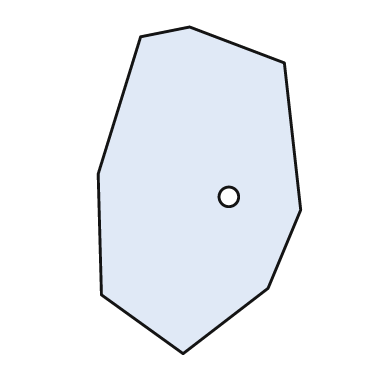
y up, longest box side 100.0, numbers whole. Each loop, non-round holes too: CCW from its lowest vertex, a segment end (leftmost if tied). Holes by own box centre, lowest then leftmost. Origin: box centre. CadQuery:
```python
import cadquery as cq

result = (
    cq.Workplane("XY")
    .moveTo(-5.0, -50.0)
    .lineTo(21.0, -30.0)
    .lineTo(31.0, -6.0)
    .lineTo(26.0, 39.0)
    .lineTo(-3.0, 50.0)
    .lineTo(-18.0, 47.0)
    .lineTo(-31.0, 5.0)
    .lineTo(-30.0, -32.0)
    .close()
    .moveTo(9.0, -2.0)
    .circle(3.0)
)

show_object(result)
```